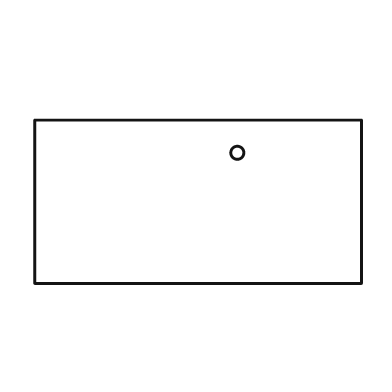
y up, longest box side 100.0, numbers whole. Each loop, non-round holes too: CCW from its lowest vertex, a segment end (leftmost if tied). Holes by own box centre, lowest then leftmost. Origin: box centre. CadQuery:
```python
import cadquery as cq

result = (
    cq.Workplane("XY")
    .moveTo(-50.0, -25.0)
    .lineTo(50.0, -25.0)
    .lineTo(50.0, 25.0)
    .lineTo(-50.0, 25.0)
    .close()
    .moveTo(12.0, 15.0)
    .circle(2.0)
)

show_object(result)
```